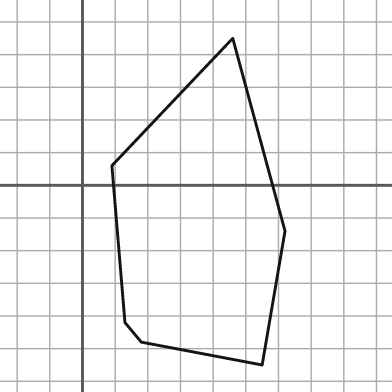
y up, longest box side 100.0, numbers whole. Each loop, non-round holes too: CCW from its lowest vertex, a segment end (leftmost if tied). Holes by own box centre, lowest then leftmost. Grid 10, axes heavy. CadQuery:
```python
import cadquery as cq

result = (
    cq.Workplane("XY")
    .moveTo(55.0, -55.0)
    .lineTo(62.0, -14.0)
    .lineTo(46.0, 45.0)
    .lineTo(9.0, 6.0)
    .lineTo(13.0, -42.0)
    .lineTo(18.0, -48.0)
    .close()
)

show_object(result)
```